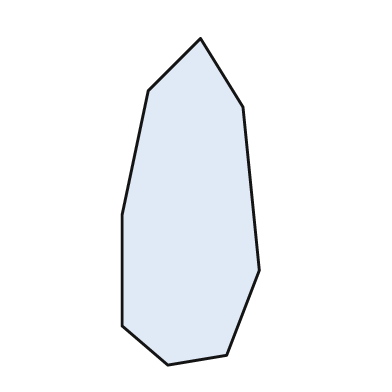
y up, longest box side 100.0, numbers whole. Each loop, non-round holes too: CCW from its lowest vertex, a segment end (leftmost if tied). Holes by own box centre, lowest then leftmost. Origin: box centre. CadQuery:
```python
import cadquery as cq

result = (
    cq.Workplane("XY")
    .moveTo(-7.0, -50.0)
    .lineTo(11.0, -47.0)
    .lineTo(21.0, -21.0)
    .lineTo(16.0, 29.0)
    .lineTo(3.0, 50.0)
    .lineTo(-13.0, 34.0)
    .lineTo(-21.0, -4.0)
    .lineTo(-21.0, -38.0)
    .close()
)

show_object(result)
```